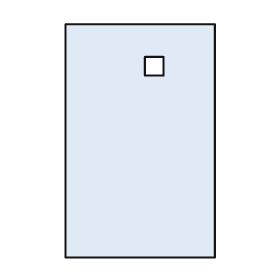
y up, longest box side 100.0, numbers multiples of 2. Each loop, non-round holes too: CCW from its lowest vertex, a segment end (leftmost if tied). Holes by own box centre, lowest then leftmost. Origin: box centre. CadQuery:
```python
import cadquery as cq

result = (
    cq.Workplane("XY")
    .moveTo(-32.0, -50.0)
    .lineTo(32.0, -50.0)
    .lineTo(32.0, 50.0)
    .lineTo(-32.0, 50.0)
    .close()
    .moveTo(2.0, 28.0)
    .lineTo(10.0, 28.0)
    .lineTo(10.0, 36.0)
    .lineTo(2.0, 36.0)
    .close()
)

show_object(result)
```